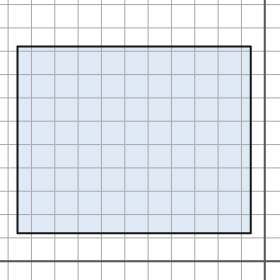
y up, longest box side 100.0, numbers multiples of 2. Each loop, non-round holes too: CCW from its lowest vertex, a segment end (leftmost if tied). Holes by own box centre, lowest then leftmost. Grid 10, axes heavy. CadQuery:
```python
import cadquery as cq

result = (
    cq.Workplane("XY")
    .moveTo(-106.0, 12.0)
    .lineTo(-6.0, 12.0)
    .lineTo(-6.0, 92.0)
    .lineTo(-106.0, 92.0)
    .close()
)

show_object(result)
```